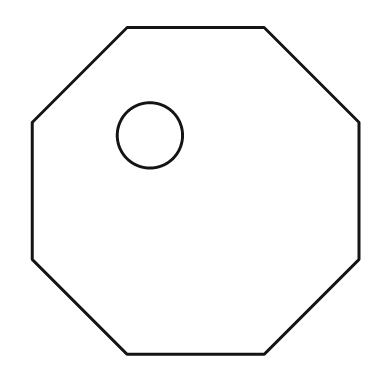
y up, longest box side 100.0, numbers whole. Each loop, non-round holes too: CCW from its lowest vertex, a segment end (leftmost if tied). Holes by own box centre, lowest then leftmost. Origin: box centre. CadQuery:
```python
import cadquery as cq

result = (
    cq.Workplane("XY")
    .moveTo(-21.0, -50.0)
    .lineTo(21.0, -50.0)
    .lineTo(50.0, -21.0)
    .lineTo(50.0, 21.0)
    .lineTo(21.0, 50.0)
    .lineTo(-21.0, 50.0)
    .lineTo(-50.0, 21.0)
    .lineTo(-50.0, -21.0)
    .close()
    .moveTo(-14.0, 17.0)
    .circle(10.0)
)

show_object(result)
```